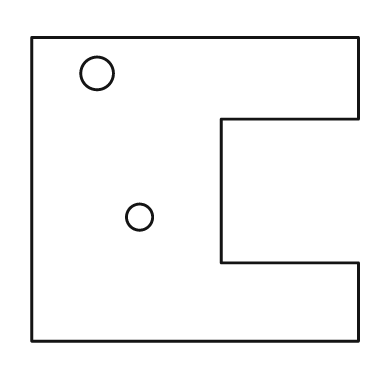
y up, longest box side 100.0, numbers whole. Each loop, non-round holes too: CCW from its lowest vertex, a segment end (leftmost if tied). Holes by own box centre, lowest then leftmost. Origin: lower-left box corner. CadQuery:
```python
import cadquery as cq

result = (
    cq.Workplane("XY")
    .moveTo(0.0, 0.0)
    .lineTo(100.0, 0.0)
    .lineTo(100.0, 24.0)
    .lineTo(58.0, 24.0)
    .lineTo(58.0, 68.0)
    .lineTo(100.0, 68.0)
    .lineTo(100.0, 93.0)
    .lineTo(0.0, 93.0)
    .close()
    .moveTo(33.0, 38.0)
    .circle(4.0)
    .moveTo(20.0, 82.0)
    .circle(5.0)
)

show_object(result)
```